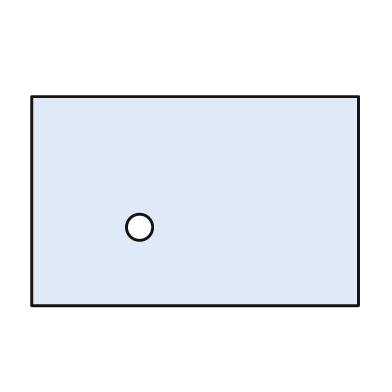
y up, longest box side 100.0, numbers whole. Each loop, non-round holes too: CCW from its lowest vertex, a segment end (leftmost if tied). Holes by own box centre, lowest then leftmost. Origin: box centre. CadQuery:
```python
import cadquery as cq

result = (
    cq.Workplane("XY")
    .moveTo(-50.0, -32.0)
    .lineTo(50.0, -32.0)
    .lineTo(50.0, 32.0)
    .lineTo(-50.0, 32.0)
    .close()
    .moveTo(-17.0, -8.0)
    .circle(4.0)
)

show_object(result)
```